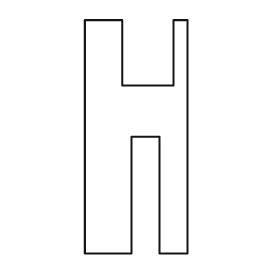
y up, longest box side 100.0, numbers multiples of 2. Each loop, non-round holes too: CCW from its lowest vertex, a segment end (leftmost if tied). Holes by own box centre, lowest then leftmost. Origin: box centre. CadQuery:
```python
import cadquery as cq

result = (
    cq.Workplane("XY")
    .moveTo(-22.0, -50.0)
    .lineTo(-2.0, -50.0)
    .lineTo(-2.0, 0.0)
    .lineTo(10.0, 0.0)
    .lineTo(10.0, -50.0)
    .lineTo(22.0, -50.0)
    .lineTo(22.0, 50.0)
    .lineTo(16.0, 50.0)
    .lineTo(16.0, 22.0)
    .lineTo(-6.0, 22.0)
    .lineTo(-6.0, 50.0)
    .lineTo(-22.0, 50.0)
    .close()
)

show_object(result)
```